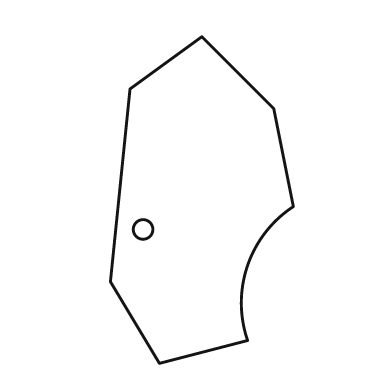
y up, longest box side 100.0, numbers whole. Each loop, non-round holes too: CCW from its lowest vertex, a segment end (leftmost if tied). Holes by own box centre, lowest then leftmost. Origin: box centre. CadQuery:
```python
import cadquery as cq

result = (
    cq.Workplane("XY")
    .moveTo(-13.0, -50.0)
    .lineTo(14.0, -43.0)
    .threePointArc((14.0, -20.0), (28.0, -2.0))
    .lineTo(22.0, 28.0)
    .lineTo(0.0, 50.0)
    .lineTo(-22.0, 34.0)
    .lineTo(-28.0, -25.0)
    .close()
    .moveTo(-18.0, -9.0)
    .circle(3.0)
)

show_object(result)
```